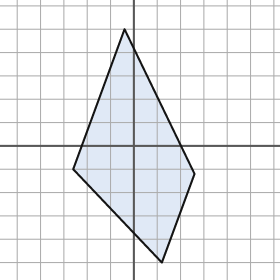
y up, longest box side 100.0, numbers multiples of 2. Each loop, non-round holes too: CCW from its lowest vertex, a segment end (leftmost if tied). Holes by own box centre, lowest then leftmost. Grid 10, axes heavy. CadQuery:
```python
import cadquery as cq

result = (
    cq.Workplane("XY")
    .moveTo(12.0, -50.0)
    .lineTo(26.0, -12.0)
    .lineTo(-4.0, 50.0)
    .lineTo(-26.0, -10.0)
    .close()
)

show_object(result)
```